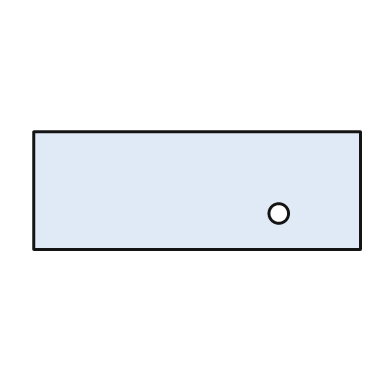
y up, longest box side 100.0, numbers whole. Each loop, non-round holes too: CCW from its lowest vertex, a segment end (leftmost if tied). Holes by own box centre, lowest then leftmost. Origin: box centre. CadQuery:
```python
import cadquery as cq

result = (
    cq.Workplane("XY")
    .moveTo(-50.0, -18.0)
    .lineTo(50.0, -18.0)
    .lineTo(50.0, 18.0)
    .lineTo(-50.0, 18.0)
    .close()
    .moveTo(25.0, -7.0)
    .circle(3.0)
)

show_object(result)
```